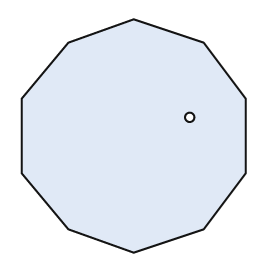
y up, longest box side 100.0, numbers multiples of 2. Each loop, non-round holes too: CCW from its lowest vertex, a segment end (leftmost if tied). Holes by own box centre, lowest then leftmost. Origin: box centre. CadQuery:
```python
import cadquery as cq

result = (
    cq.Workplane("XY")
    .moveTo(0.0, -50.0)
    .lineTo(30.0, -40.0)
    .lineTo(48.0, -16.0)
    .lineTo(48.0, 16.0)
    .lineTo(30.0, 40.0)
    .lineTo(0.0, 50.0)
    .lineTo(-28.0, 40.0)
    .lineTo(-48.0, 16.0)
    .lineTo(-48.0, -16.0)
    .lineTo(-28.0, -40.0)
    .close()
    .moveTo(24.0, 8.0)
    .circle(2.0)
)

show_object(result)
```